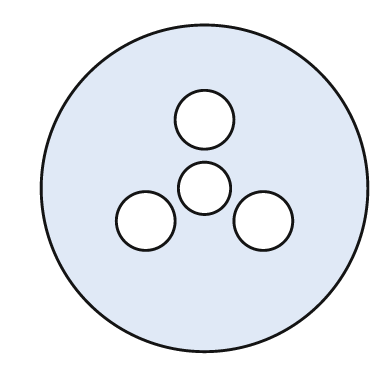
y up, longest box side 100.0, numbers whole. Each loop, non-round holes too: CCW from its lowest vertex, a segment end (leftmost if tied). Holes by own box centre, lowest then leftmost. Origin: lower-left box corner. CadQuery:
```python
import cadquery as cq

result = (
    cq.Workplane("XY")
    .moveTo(50.0, 50.0)
    .circle(50.0)
    .moveTo(32.0, 40.0)
    .circle(9.0)
    .moveTo(68.0, 40.0)
    .circle(9.0)
    .moveTo(50.0, 50.0)
    .circle(8.0)
    .moveTo(50.0, 71.0)
    .circle(9.0)
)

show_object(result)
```